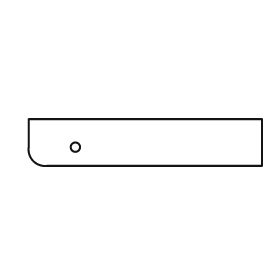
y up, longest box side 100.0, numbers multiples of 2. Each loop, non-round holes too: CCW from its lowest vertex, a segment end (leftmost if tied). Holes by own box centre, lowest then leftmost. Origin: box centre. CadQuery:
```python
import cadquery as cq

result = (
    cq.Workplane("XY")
    .moveTo(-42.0, -10.0)
    .lineTo(50.0, -10.0)
    .lineTo(50.0, 10.0)
    .lineTo(-50.0, 10.0)
    .lineTo(-50.0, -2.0)
    .threePointArc((-48.0, -8.0), (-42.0, -10.0))
    .close()
    .moveTo(-30.0, -2.0)
    .circle(2.0)
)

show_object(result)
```